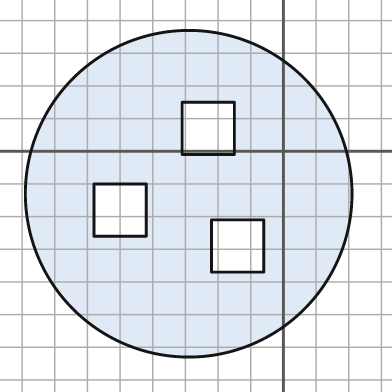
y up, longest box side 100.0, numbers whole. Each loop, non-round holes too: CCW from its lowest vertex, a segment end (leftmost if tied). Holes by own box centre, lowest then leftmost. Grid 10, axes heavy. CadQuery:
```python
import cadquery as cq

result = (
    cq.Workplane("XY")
    .moveTo(-29.0, -13.0)
    .circle(50.0)
    .moveTo(-22.0, -37.0)
    .lineTo(-6.0, -37.0)
    .lineTo(-6.0, -21.0)
    .lineTo(-22.0, -21.0)
    .close()
    .moveTo(-58.0, -26.0)
    .lineTo(-42.0, -26.0)
    .lineTo(-42.0, -10.0)
    .lineTo(-58.0, -10.0)
    .close()
    .moveTo(-31.0, -1.0)
    .lineTo(-15.0, -1.0)
    .lineTo(-15.0, 15.0)
    .lineTo(-31.0, 15.0)
    .close()
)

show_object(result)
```